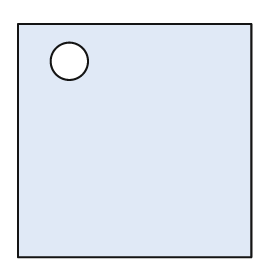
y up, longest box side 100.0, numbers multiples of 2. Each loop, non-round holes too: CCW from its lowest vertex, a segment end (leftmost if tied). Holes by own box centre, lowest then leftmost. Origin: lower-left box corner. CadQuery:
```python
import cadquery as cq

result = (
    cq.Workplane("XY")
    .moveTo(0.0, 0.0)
    .lineTo(100.0, 0.0)
    .lineTo(100.0, 100.0)
    .lineTo(0.0, 100.0)
    .close()
    .moveTo(22.0, 84.0)
    .circle(8.0)
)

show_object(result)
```